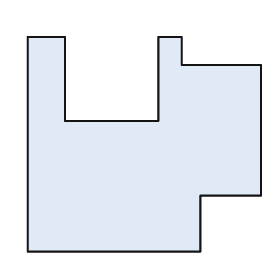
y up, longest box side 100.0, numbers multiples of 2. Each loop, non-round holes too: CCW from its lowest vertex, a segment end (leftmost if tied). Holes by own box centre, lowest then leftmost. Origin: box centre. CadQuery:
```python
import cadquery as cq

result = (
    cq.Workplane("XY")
    .moveTo(-50.0, -46.0)
    .lineTo(24.0, -46.0)
    .lineTo(24.0, -22.0)
    .lineTo(50.0, -22.0)
    .lineTo(50.0, 34.0)
    .lineTo(16.0, 34.0)
    .lineTo(16.0, 46.0)
    .lineTo(6.0, 46.0)
    .lineTo(6.0, 10.0)
    .lineTo(-34.0, 10.0)
    .lineTo(-34.0, 46.0)
    .lineTo(-50.0, 46.0)
    .close()
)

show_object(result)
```